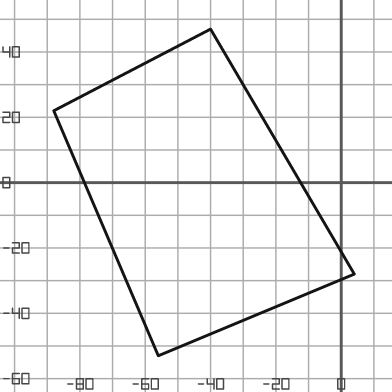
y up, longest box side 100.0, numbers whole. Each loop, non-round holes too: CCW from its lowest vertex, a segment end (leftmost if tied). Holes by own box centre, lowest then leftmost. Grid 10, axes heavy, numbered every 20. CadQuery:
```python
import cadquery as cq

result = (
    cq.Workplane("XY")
    .moveTo(-56.0, -53.0)
    .lineTo(4.0, -28.0)
    .lineTo(-40.0, 47.0)
    .lineTo(-88.0, 22.0)
    .close()
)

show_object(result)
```